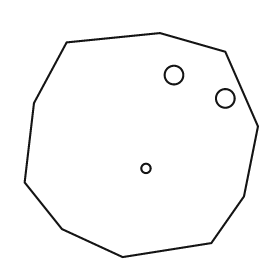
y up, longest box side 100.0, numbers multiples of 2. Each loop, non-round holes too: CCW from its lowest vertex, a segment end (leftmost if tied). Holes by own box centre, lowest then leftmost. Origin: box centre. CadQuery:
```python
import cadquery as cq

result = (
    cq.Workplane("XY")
    .moveTo(-8.0, -48.0)
    .lineTo(30.0, -42.0)
    .lineTo(44.0, -22.0)
    .lineTo(50.0, 8.0)
    .lineTo(36.0, 40.0)
    .lineTo(8.0, 48.0)
    .lineTo(-32.0, 44.0)
    .lineTo(-46.0, 18.0)
    .lineTo(-50.0, -16.0)
    .lineTo(-34.0, -36.0)
    .close()
    .moveTo(2.0, -10.0)
    .circle(2.0)
    .moveTo(36.0, 20.0)
    .circle(4.0)
    .moveTo(14.0, 30.0)
    .circle(4.0)
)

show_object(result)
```